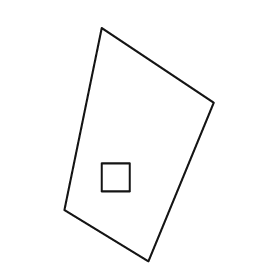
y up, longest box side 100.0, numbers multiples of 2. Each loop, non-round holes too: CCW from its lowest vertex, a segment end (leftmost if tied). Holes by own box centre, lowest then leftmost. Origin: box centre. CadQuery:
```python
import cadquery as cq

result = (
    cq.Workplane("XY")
    .moveTo(4.0, -50.0)
    .lineTo(32.0, 18.0)
    .lineTo(-16.0, 50.0)
    .lineTo(-32.0, -28.0)
    .close()
    .moveTo(-16.0, -20.0)
    .lineTo(-4.0, -20.0)
    .lineTo(-4.0, -8.0)
    .lineTo(-16.0, -8.0)
    .close()
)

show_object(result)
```